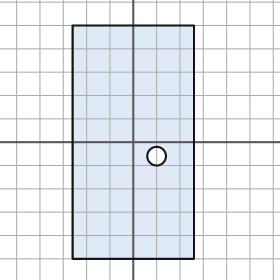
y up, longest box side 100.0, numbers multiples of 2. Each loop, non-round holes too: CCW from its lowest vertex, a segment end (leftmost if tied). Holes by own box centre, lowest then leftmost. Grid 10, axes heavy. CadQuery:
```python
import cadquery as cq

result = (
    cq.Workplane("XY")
    .moveTo(-26.0, -50.0)
    .lineTo(26.0, -50.0)
    .lineTo(26.0, 50.0)
    .lineTo(-26.0, 50.0)
    .close()
    .moveTo(10.0, -6.0)
    .circle(4.0)
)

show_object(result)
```